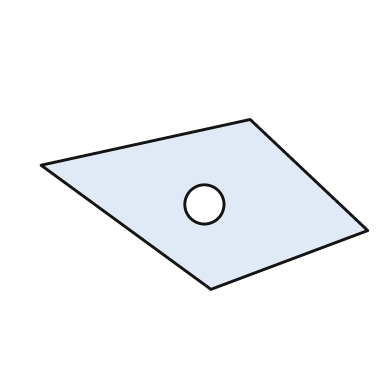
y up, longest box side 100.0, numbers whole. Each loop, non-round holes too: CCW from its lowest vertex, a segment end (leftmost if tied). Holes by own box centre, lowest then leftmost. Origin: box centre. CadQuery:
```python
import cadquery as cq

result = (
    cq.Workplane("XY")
    .moveTo(2.0, -26.0)
    .lineTo(50.0, -8.0)
    .lineTo(14.0, 26.0)
    .lineTo(-50.0, 12.0)
    .close()
    .moveTo(0.0, 0.0)
    .circle(6.0)
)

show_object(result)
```